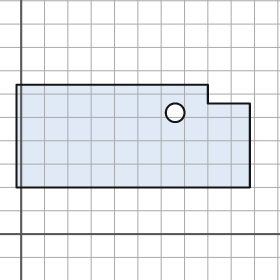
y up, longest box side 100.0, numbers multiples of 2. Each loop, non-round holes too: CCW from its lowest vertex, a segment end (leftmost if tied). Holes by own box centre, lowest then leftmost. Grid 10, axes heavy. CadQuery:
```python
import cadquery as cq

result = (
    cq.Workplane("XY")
    .moveTo(-2.0, 20.0)
    .lineTo(98.0, 20.0)
    .lineTo(98.0, 56.0)
    .lineTo(80.0, 56.0)
    .lineTo(80.0, 64.0)
    .lineTo(-2.0, 64.0)
    .close()
    .moveTo(66.0, 52.0)
    .circle(4.0)
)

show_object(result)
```